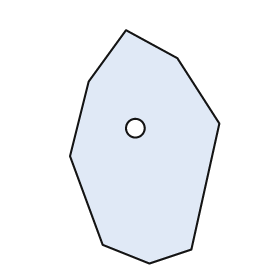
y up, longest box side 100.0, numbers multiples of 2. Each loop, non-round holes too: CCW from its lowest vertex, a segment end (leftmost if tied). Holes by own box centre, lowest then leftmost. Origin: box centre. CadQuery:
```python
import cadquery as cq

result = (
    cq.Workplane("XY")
    .moveTo(2.0, -50.0)
    .lineTo(20.0, -44.0)
    .lineTo(32.0, 10.0)
    .lineTo(14.0, 38.0)
    .lineTo(-8.0, 50.0)
    .lineTo(-24.0, 28.0)
    .lineTo(-32.0, -4.0)
    .lineTo(-18.0, -42.0)
    .close()
    .moveTo(-4.0, 8.0)
    .circle(4.0)
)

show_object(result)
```